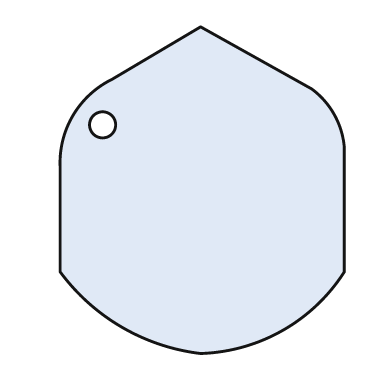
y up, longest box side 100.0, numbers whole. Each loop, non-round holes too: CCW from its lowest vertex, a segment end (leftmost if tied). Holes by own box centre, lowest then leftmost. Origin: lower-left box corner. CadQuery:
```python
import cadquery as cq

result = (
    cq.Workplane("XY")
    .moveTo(43.0, 0.0)
    .threePointArc((68.0, 7.0), (87.0, 25.0))
    .lineTo(87.0, 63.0)
    .threePointArc((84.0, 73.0), (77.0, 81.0))
    .lineTo(43.0, 100.0)
    .lineTo(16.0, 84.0)
    .threePointArc((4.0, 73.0), (0.0, 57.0))
    .lineTo(0.0, 25.0)
    .threePointArc((19.0, 8.0), (43.0, 0.0))
    .close()
    .moveTo(13.0, 70.0)
    .circle(4.0)
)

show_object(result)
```